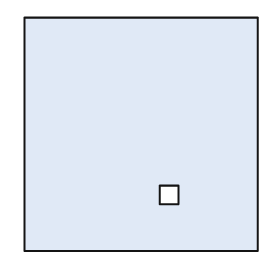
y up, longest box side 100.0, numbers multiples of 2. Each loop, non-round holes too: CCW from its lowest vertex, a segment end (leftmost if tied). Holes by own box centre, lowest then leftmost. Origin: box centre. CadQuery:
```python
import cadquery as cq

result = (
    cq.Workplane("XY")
    .moveTo(-50.0, -50.0)
    .lineTo(50.0, -50.0)
    .lineTo(50.0, 50.0)
    .lineTo(-50.0, 50.0)
    .close()
    .moveTo(8.0, -30.0)
    .lineTo(16.0, -30.0)
    .lineTo(16.0, -22.0)
    .lineTo(8.0, -22.0)
    .close()
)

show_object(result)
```